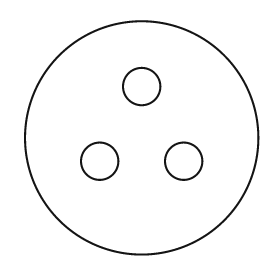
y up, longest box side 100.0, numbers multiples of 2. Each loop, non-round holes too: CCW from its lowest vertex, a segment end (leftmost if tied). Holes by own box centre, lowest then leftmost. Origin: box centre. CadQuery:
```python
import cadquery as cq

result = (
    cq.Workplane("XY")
    .moveTo(0.0, 0.0)
    .circle(50.0)
    .moveTo(-18.0, -10.0)
    .circle(8.0)
    .moveTo(18.0, -10.0)
    .circle(8.0)
    .moveTo(0.0, 22.0)
    .circle(8.0)
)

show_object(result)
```